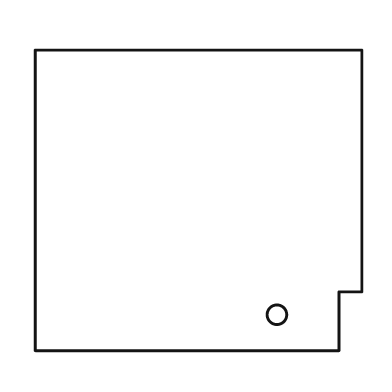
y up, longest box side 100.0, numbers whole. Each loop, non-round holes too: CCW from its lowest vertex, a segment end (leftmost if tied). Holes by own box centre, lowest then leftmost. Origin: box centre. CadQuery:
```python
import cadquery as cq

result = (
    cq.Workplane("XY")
    .moveTo(-50.0, -46.0)
    .lineTo(43.0, -46.0)
    .lineTo(43.0, -28.0)
    .lineTo(50.0, -28.0)
    .lineTo(50.0, 46.0)
    .lineTo(-50.0, 46.0)
    .close()
    .moveTo(24.0, -35.0)
    .circle(3.0)
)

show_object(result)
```